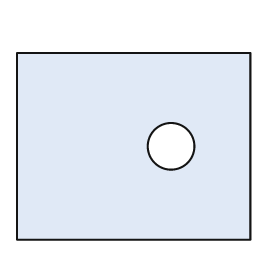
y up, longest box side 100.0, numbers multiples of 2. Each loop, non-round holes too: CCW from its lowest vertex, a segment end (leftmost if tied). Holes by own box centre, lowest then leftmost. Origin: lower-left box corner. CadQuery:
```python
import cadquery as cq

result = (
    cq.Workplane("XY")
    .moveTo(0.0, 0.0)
    .lineTo(100.0, 0.0)
    .lineTo(100.0, 80.0)
    .lineTo(0.0, 80.0)
    .close()
    .moveTo(66.0, 40.0)
    .circle(10.0)
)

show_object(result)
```